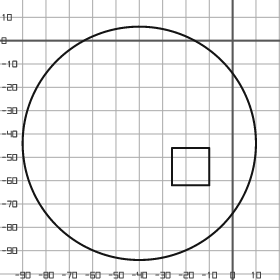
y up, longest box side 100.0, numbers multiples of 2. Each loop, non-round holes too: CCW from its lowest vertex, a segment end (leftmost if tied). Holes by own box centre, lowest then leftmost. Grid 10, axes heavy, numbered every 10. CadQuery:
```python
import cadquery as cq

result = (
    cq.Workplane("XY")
    .moveTo(-40.0, -44.0)
    .circle(50.0)
    .moveTo(-26.0, -62.0)
    .lineTo(-10.0, -62.0)
    .lineTo(-10.0, -46.0)
    .lineTo(-26.0, -46.0)
    .close()
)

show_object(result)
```